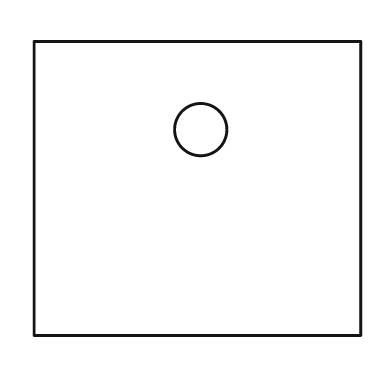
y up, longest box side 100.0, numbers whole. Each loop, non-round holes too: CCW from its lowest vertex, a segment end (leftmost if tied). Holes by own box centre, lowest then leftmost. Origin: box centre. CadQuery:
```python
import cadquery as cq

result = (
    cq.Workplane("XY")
    .moveTo(-50.0, -45.0)
    .lineTo(50.0, -45.0)
    .lineTo(50.0, 45.0)
    .lineTo(-50.0, 45.0)
    .close()
    .moveTo(1.0, 18.0)
    .circle(8.0)
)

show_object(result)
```